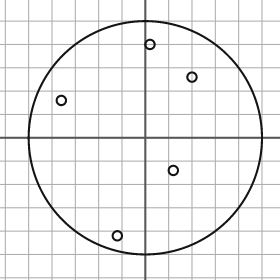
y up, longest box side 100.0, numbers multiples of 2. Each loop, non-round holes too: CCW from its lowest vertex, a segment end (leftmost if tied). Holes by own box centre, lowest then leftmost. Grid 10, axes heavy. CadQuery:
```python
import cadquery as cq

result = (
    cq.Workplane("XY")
    .moveTo(0.0, 0.0)
    .circle(50.0)
    .moveTo(-12.0, -42.0)
    .circle(2.0)
    .moveTo(12.0, -14.0)
    .circle(2.0)
    .moveTo(-36.0, 16.0)
    .circle(2.0)
    .moveTo(20.0, 26.0)
    .circle(2.0)
    .moveTo(2.0, 40.0)
    .circle(2.0)
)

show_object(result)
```